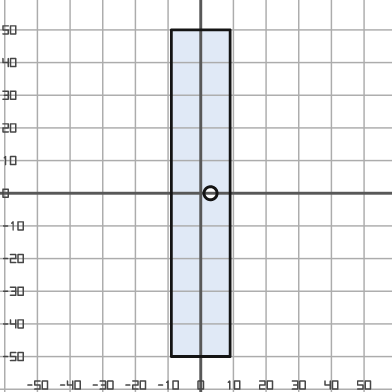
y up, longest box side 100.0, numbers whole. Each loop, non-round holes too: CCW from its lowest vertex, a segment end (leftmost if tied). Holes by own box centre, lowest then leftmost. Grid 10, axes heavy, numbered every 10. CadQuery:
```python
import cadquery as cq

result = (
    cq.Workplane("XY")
    .moveTo(-9.0, -50.0)
    .lineTo(9.0, -50.0)
    .lineTo(9.0, 50.0)
    .lineTo(-9.0, 50.0)
    .close()
    .moveTo(3.0, 0.0)
    .circle(2.0)
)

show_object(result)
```